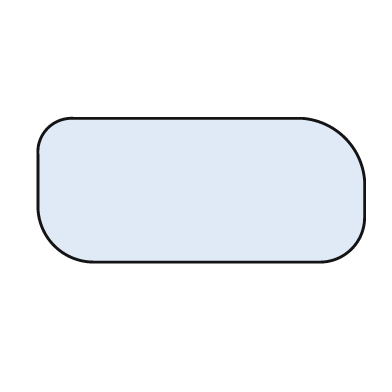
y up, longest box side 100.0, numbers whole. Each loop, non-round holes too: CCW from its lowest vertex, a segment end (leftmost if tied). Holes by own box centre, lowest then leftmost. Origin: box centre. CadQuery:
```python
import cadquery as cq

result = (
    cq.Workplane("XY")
    .moveTo(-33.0, -22.0)
    .lineTo(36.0, -22.0)
    .threePointArc((46.0, -18.0), (50.0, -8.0))
    .lineTo(50.0, 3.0)
    .threePointArc((44.0, 16.0), (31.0, 22.0))
    .lineTo(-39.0, 22.0)
    .threePointArc((-47.0, 19.0), (-50.0, 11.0))
    .lineTo(-50.0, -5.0)
    .threePointArc((-45.0, -17.0), (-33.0, -22.0))
    .close()
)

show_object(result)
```